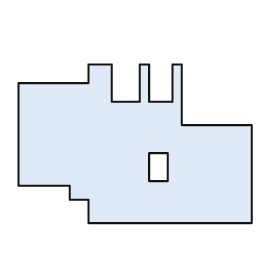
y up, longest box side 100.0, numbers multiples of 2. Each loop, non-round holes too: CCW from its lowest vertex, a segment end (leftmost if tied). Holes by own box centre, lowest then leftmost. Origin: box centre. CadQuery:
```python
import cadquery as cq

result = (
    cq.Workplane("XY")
    .moveTo(-20.0, -34.0)
    .lineTo(50.0, -34.0)
    .lineTo(50.0, 8.0)
    .lineTo(20.0, 8.0)
    .lineTo(20.0, 34.0)
    .lineTo(16.0, 34.0)
    .lineTo(16.0, 18.0)
    .lineTo(6.0, 18.0)
    .lineTo(6.0, 34.0)
    .lineTo(2.0, 34.0)
    .lineTo(2.0, 18.0)
    .lineTo(-10.0, 18.0)
    .lineTo(-10.0, 34.0)
    .lineTo(-20.0, 34.0)
    .lineTo(-20.0, 26.0)
    .lineTo(-50.0, 26.0)
    .lineTo(-50.0, -18.0)
    .lineTo(-28.0, -18.0)
    .lineTo(-28.0, -24.0)
    .lineTo(-20.0, -24.0)
    .close()
    .moveTo(6.0, -16.0)
    .lineTo(14.0, -16.0)
    .lineTo(14.0, -4.0)
    .lineTo(6.0, -4.0)
    .close()
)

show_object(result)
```